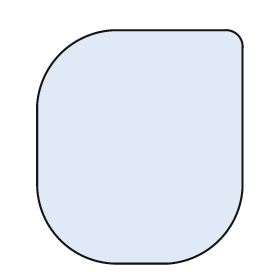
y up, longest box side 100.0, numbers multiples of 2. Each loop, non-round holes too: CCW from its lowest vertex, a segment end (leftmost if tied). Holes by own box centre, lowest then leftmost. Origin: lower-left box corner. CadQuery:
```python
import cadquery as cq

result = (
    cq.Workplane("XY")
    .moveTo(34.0, 0.0)
    .lineTo(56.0, 0.0)
    .threePointArc((78.0, 10.0), (88.0, 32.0))
    .lineTo(88.0, 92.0)
    .threePointArc((86.0, 98.0), (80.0, 100.0))
    .lineTo(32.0, 100.0)
    .threePointArc((10.0, 90.0), (0.0, 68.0))
    .lineTo(0.0, 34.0)
    .threePointArc((10.0, 10.0), (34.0, 0.0))
    .close()
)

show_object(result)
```